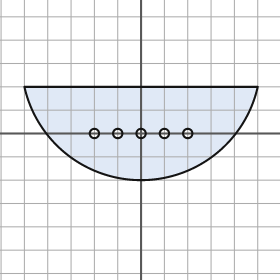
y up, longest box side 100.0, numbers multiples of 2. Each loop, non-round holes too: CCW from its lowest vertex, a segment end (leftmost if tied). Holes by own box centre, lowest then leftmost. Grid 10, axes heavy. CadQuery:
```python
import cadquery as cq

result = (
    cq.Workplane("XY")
    .moveTo(-50.0, 20.0)
    .threePointArc((0.0, -20.0), (50.0, 20.0))
    .close()
    .moveTo(-20.0, 0.0)
    .circle(2.0)
    .moveTo(-10.0, 0.0)
    .circle(2.0)
    .moveTo(0.0, 0.0)
    .circle(2.0)
    .moveTo(10.0, 0.0)
    .circle(2.0)
    .moveTo(20.0, 0.0)
    .circle(2.0)
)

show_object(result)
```